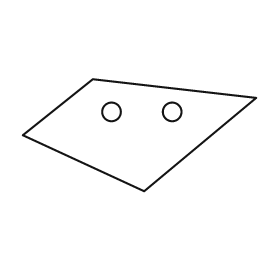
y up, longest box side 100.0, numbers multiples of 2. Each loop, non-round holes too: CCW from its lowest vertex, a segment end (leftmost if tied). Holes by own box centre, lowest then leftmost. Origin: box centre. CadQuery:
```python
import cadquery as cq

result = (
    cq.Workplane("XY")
    .moveTo(2.0, -24.0)
    .lineTo(50.0, 16.0)
    .lineTo(-20.0, 24.0)
    .lineTo(-50.0, 0.0)
    .close()
    .moveTo(-12.0, 10.0)
    .circle(4.0)
    .moveTo(14.0, 10.0)
    .circle(4.0)
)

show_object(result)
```